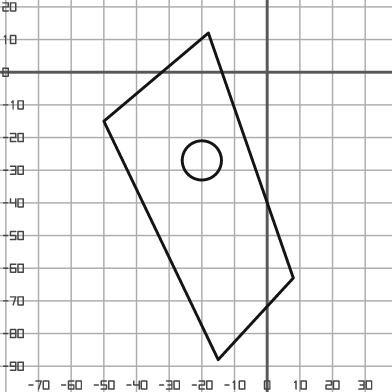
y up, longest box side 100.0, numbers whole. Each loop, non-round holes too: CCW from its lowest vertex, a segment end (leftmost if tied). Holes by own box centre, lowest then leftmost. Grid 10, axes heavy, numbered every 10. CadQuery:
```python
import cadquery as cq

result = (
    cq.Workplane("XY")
    .moveTo(-15.0, -88.0)
    .lineTo(8.0, -63.0)
    .lineTo(-18.0, 12.0)
    .lineTo(-50.0, -15.0)
    .close()
    .moveTo(-20.0, -27.0)
    .circle(6.0)
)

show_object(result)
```